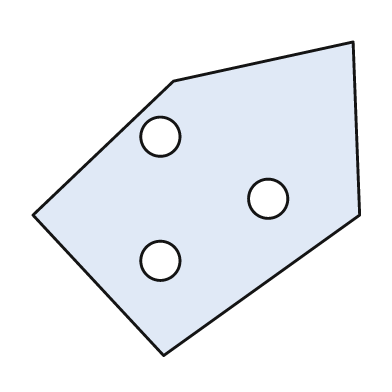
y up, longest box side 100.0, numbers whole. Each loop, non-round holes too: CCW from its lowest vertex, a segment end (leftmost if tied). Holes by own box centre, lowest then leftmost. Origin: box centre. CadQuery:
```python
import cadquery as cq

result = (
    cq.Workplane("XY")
    .moveTo(-10.0, -48.0)
    .lineTo(50.0, -5.0)
    .lineTo(48.0, 48.0)
    .lineTo(-7.0, 36.0)
    .lineTo(-50.0, -5.0)
    .close()
    .moveTo(-11.0, -19.0)
    .circle(6.0)
    .moveTo(22.0, 0.0)
    .circle(6.0)
    .moveTo(-11.0, 19.0)
    .circle(6.0)
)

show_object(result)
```